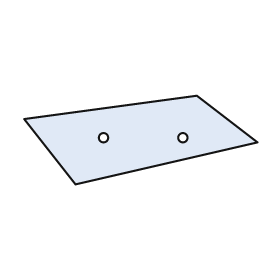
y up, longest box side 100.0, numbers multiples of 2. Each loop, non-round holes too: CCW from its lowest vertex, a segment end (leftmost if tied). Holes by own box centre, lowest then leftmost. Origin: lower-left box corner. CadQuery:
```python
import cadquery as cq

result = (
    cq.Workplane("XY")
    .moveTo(22.0, 0.0)
    .lineTo(100.0, 18.0)
    .lineTo(74.0, 38.0)
    .lineTo(0.0, 28.0)
    .close()
    .moveTo(34.0, 20.0)
    .circle(2.0)
    .moveTo(68.0, 20.0)
    .circle(2.0)
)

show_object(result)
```